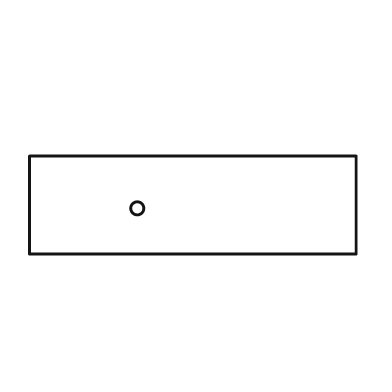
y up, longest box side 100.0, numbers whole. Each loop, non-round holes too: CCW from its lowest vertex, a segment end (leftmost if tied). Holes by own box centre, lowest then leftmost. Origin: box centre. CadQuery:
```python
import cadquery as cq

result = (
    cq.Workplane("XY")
    .moveTo(-50.0, -15.0)
    .lineTo(50.0, -15.0)
    .lineTo(50.0, 15.0)
    .lineTo(-50.0, 15.0)
    .close()
    .moveTo(-17.0, -1.0)
    .circle(2.0)
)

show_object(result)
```